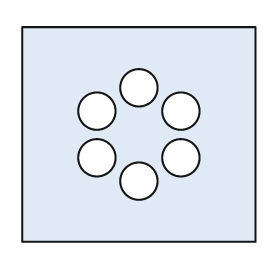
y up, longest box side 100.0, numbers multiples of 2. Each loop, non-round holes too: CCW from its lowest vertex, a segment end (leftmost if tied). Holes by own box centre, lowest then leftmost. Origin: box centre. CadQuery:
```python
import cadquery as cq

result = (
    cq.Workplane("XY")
    .moveTo(-50.0, -46.0)
    .lineTo(50.0, -46.0)
    .lineTo(50.0, 46.0)
    .lineTo(-50.0, 46.0)
    .close()
    .moveTo(0.0, -20.0)
    .circle(8.0)
    .moveTo(-18.0, -10.0)
    .circle(8.0)
    .moveTo(18.0, -10.0)
    .circle(8.0)
    .moveTo(-18.0, 10.0)
    .circle(8.0)
    .moveTo(18.0, 10.0)
    .circle(8.0)
    .moveTo(0.0, 20.0)
    .circle(8.0)
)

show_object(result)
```